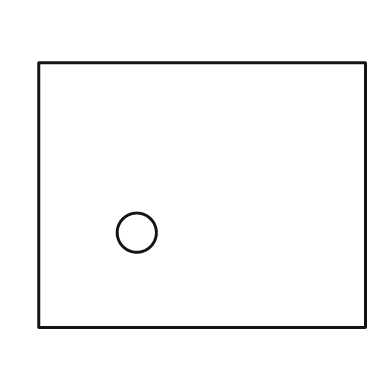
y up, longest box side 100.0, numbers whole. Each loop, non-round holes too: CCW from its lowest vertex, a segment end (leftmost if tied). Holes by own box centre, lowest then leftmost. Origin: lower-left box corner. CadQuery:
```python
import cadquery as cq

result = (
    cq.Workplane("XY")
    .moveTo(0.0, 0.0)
    .lineTo(100.0, 0.0)
    .lineTo(100.0, 81.0)
    .lineTo(0.0, 81.0)
    .close()
    .moveTo(30.0, 29.0)
    .circle(6.0)
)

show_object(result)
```